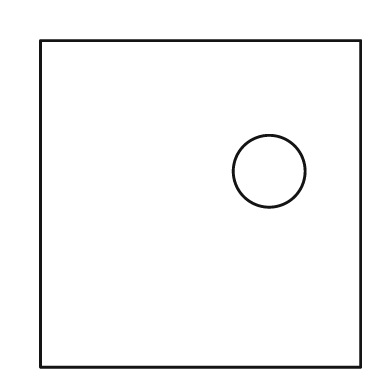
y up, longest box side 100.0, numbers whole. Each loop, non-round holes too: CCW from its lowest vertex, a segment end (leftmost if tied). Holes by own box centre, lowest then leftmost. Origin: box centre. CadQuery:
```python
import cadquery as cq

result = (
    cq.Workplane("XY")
    .moveTo(-49.0, -50.0)
    .lineTo(49.0, -50.0)
    .lineTo(49.0, 50.0)
    .lineTo(-49.0, 50.0)
    .close()
    .moveTo(21.0, 10.0)
    .circle(11.0)
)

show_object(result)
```